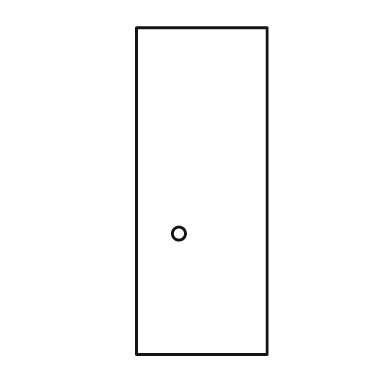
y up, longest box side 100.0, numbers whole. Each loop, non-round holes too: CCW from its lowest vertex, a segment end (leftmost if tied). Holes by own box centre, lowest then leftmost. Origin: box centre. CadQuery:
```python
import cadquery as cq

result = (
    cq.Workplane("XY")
    .moveTo(-20.0, -50.0)
    .lineTo(20.0, -50.0)
    .lineTo(20.0, 50.0)
    .lineTo(-20.0, 50.0)
    .close()
    .moveTo(-7.0, -13.0)
    .circle(2.0)
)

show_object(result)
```